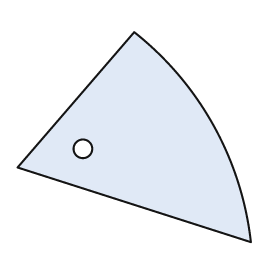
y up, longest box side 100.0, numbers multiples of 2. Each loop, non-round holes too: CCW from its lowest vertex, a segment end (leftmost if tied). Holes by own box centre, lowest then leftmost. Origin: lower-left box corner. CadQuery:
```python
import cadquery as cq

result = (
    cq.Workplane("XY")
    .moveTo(100.0, 0.0)
    .threePointArc((84.0, 50.0), (50.0, 90.0))
    .lineTo(0.0, 32.0)
    .close()
    .moveTo(28.0, 40.0)
    .circle(4.0)
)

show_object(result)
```